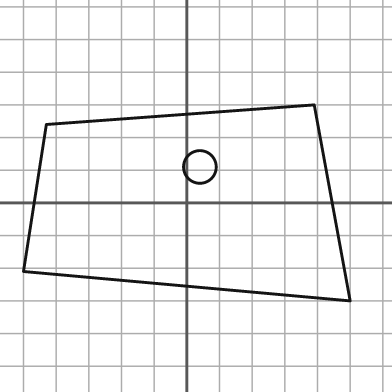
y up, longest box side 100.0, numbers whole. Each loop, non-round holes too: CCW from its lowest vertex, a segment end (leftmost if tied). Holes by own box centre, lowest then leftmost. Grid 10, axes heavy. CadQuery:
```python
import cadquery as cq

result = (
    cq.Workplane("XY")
    .moveTo(50.0, -30.0)
    .lineTo(39.0, 30.0)
    .lineTo(-43.0, 24.0)
    .lineTo(-50.0, -21.0)
    .close()
    .moveTo(4.0, 11.0)
    .circle(5.0)
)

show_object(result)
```